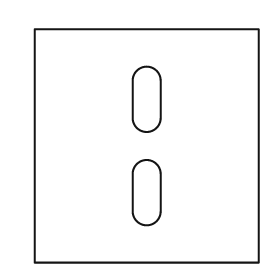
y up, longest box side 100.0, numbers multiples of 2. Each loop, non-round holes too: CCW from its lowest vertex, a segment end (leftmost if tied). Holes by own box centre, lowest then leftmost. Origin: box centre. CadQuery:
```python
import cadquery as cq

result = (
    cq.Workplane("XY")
    .moveTo(-48.0, -50.0)
    .lineTo(48.0, -50.0)
    .lineTo(48.0, 50.0)
    .lineTo(-48.0, 50.0)
    .close()
    .moveTo(-6.0, -28.0)
    .threePointArc((0.0, -34.0), (6.0, -28.0))
    .lineTo(6.0, -12.0)
    .threePointArc((0.0, -6.0), (-6.0, -12.0))
    .close()
    .moveTo(-6.0, 12.0)
    .threePointArc((0.0, 6.0), (6.0, 12.0))
    .lineTo(6.0, 28.0)
    .threePointArc((0.0, 34.0), (-6.0, 28.0))
    .close()
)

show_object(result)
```